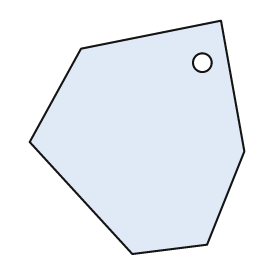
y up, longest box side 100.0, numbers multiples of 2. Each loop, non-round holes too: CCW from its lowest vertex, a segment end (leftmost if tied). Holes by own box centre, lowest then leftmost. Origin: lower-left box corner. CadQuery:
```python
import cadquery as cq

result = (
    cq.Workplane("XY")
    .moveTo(44.0, 0.0)
    .lineTo(76.0, 4.0)
    .lineTo(92.0, 44.0)
    .lineTo(82.0, 100.0)
    .lineTo(22.0, 88.0)
    .lineTo(0.0, 48.0)
    .close()
    .moveTo(74.0, 82.0)
    .circle(4.0)
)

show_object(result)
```